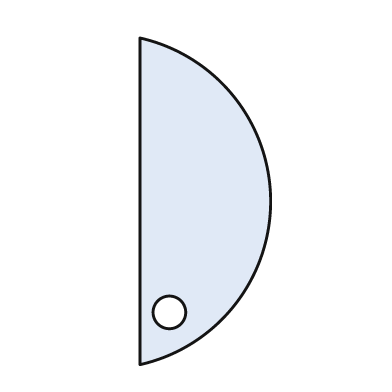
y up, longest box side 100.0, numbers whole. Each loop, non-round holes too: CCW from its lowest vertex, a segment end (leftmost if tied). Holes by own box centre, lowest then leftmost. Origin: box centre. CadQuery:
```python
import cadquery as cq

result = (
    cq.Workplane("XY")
    .moveTo(-20.0, -50.0)
    .threePointArc((20.0, 0.0), (-20.0, 50.0))
    .close()
    .moveTo(-11.0, -34.0)
    .circle(5.0)
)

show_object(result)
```